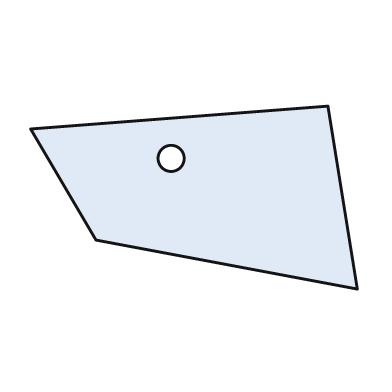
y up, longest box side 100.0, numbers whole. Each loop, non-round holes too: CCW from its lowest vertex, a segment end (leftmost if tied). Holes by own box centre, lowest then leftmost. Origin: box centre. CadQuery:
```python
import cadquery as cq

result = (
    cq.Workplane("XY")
    .moveTo(50.0, -28.0)
    .lineTo(41.0, 28.0)
    .lineTo(-50.0, 21.0)
    .lineTo(-30.0, -13.0)
    .close()
    .moveTo(-7.0, 12.0)
    .circle(4.0)
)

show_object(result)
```